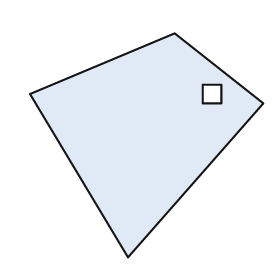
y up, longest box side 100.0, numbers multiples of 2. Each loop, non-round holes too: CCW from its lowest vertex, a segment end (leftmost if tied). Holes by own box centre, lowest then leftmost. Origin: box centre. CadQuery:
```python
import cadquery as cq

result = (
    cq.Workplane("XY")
    .moveTo(-8.0, -48.0)
    .lineTo(50.0, 18.0)
    .lineTo(12.0, 48.0)
    .lineTo(-50.0, 22.0)
    .close()
    .moveTo(24.0, 18.0)
    .lineTo(32.0, 18.0)
    .lineTo(32.0, 26.0)
    .lineTo(24.0, 26.0)
    .close()
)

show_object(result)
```